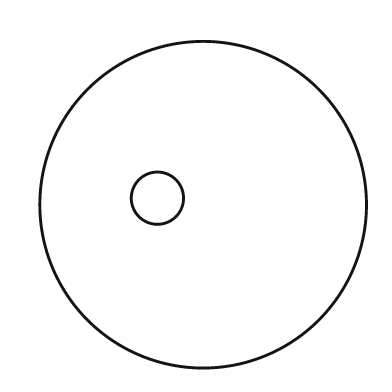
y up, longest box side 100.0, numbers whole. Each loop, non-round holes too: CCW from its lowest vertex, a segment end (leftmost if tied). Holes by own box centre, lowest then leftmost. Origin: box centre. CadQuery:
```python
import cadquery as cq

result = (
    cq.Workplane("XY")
    .moveTo(0.0, 0.0)
    .circle(50.0)
    .moveTo(-14.0, 2.0)
    .circle(8.0)
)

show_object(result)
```